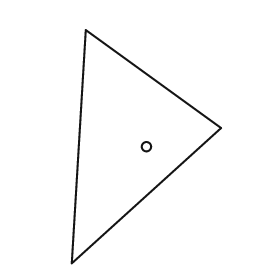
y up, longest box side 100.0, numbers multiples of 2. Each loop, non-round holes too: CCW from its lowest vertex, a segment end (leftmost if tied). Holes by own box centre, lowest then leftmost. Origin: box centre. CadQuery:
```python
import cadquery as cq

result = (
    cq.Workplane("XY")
    .moveTo(-32.0, -50.0)
    .lineTo(32.0, 8.0)
    .lineTo(-26.0, 50.0)
    .close()
    .moveTo(0.0, 0.0)
    .circle(2.0)
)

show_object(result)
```